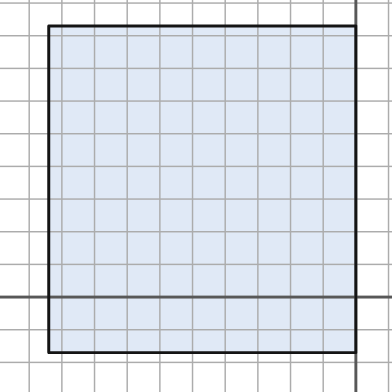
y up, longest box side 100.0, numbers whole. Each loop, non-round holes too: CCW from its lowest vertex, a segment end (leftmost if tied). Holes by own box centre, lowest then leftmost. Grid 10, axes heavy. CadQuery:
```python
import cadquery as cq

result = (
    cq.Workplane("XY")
    .moveTo(-94.0, -17.0)
    .lineTo(0.0, -17.0)
    .lineTo(0.0, 83.0)
    .lineTo(-94.0, 83.0)
    .close()
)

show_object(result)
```